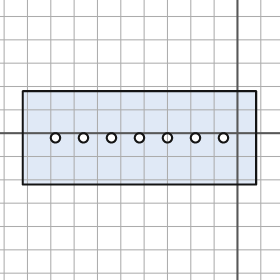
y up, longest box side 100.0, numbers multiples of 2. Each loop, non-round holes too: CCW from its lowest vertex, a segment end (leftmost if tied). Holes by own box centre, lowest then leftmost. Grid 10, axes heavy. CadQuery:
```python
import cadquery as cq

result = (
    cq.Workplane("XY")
    .moveTo(-92.0, -22.0)
    .lineTo(8.0, -22.0)
    .lineTo(8.0, 18.0)
    .lineTo(-92.0, 18.0)
    .close()
    .moveTo(-78.0, -2.0)
    .circle(2.0)
    .moveTo(-66.0, -2.0)
    .circle(2.0)
    .moveTo(-54.0, -2.0)
    .circle(2.0)
    .moveTo(-42.0, -2.0)
    .circle(2.0)
    .moveTo(-30.0, -2.0)
    .circle(2.0)
    .moveTo(-18.0, -2.0)
    .circle(2.0)
    .moveTo(-6.0, -2.0)
    .circle(2.0)
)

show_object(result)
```